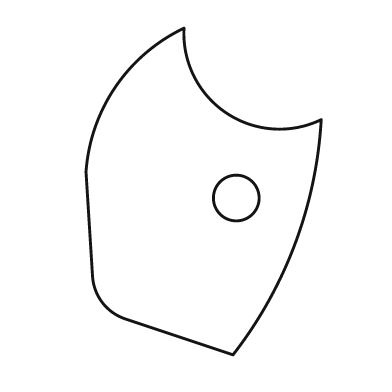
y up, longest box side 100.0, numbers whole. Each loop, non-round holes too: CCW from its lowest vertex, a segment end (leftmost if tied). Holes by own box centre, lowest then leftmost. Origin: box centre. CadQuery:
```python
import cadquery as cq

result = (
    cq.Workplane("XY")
    .moveTo(9.0, -50.0)
    .threePointArc((28.0, -16.0), (36.0, 22.0))
    .threePointArc((7.0, 24.0), (-6.0, 50.0))
    .threePointArc((-27.0, 32.0), (-36.0, 6.0))
    .lineTo(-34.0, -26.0)
    .threePointArc((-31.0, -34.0), (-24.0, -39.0))
    .close()
    .moveTo(10.0, -2.0)
    .circle(7.0)
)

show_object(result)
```